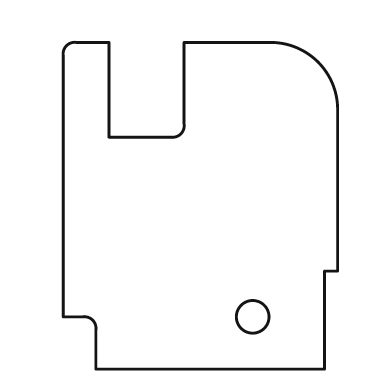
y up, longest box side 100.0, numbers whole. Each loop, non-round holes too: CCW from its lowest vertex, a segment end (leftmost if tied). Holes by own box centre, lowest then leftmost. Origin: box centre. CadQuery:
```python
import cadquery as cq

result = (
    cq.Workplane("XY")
    .moveTo(-32.0, -50.0)
    .lineTo(38.0, -50.0)
    .lineTo(38.0, -20.0)
    .lineTo(42.0, -20.0)
    .lineTo(42.0, 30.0)
    .threePointArc((36.0, 44.0), (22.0, 50.0))
    .lineTo(-5.0, 50.0)
    .lineTo(-5.0, 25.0)
    .threePointArc((-6.0, 22.0), (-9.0, 21.0))
    .lineTo(-28.0, 21.0)
    .lineTo(-28.0, 50.0)
    .lineTo(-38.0, 50.0)
    .threePointArc((-41.0, 49.0), (-42.0, 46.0))
    .lineTo(-42.0, -34.0)
    .lineTo(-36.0, -34.0)
    .threePointArc((-33.0, -35.0), (-32.0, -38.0))
    .close()
    .moveTo(16.0, -34.0)
    .circle(5.0)
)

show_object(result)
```